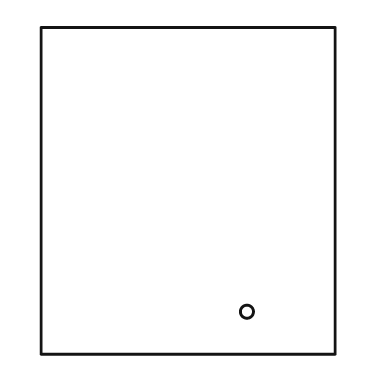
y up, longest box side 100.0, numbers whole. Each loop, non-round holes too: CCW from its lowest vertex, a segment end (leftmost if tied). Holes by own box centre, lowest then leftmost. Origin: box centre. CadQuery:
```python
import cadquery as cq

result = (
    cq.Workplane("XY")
    .moveTo(-45.0, -50.0)
    .lineTo(45.0, -50.0)
    .lineTo(45.0, 50.0)
    .lineTo(-45.0, 50.0)
    .close()
    .moveTo(18.0, -37.0)
    .circle(2.0)
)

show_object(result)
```